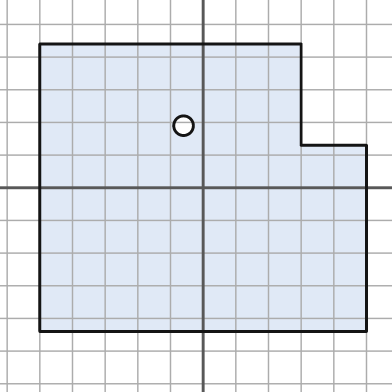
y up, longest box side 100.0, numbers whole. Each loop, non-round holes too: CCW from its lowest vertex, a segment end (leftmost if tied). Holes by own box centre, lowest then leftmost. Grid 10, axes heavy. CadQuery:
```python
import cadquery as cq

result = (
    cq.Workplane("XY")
    .moveTo(-50.0, -44.0)
    .lineTo(50.0, -44.0)
    .lineTo(50.0, 13.0)
    .lineTo(30.0, 13.0)
    .lineTo(30.0, 44.0)
    .lineTo(-50.0, 44.0)
    .close()
    .moveTo(-6.0, 19.0)
    .circle(3.0)
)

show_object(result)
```